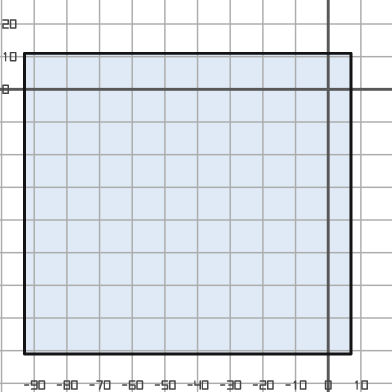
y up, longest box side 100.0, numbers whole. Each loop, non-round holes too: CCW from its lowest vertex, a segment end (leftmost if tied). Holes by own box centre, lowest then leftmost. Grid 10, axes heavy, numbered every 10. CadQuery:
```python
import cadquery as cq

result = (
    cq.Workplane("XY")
    .moveTo(-93.0, -81.0)
    .lineTo(7.0, -81.0)
    .lineTo(7.0, 11.0)
    .lineTo(-93.0, 11.0)
    .close()
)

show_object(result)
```